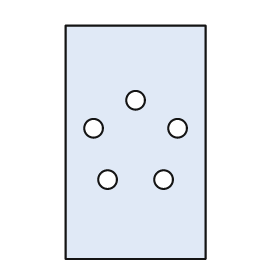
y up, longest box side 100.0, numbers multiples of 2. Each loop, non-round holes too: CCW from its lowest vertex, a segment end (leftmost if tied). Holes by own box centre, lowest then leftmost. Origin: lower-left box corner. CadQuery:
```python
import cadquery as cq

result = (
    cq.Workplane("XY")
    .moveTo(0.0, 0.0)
    .lineTo(60.0, 0.0)
    .lineTo(60.0, 100.0)
    .lineTo(0.0, 100.0)
    .close()
    .moveTo(18.0, 34.0)
    .circle(4.0)
    .moveTo(42.0, 34.0)
    .circle(4.0)
    .moveTo(12.0, 56.0)
    .circle(4.0)
    .moveTo(48.0, 56.0)
    .circle(4.0)
    .moveTo(30.0, 68.0)
    .circle(4.0)
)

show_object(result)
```